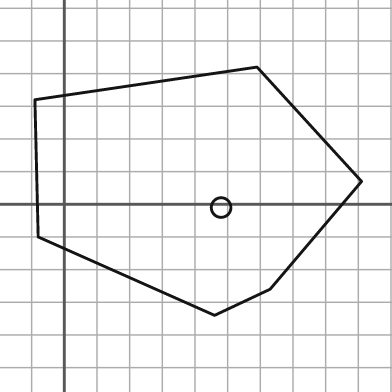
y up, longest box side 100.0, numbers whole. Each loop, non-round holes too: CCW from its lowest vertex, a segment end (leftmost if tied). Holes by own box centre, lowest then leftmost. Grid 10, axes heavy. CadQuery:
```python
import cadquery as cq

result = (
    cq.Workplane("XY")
    .moveTo(46.0, -34.0)
    .lineTo(63.0, -26.0)
    .lineTo(91.0, 7.0)
    .lineTo(59.0, 42.0)
    .lineTo(-9.0, 32.0)
    .lineTo(-8.0, -10.0)
    .close()
    .moveTo(48.0, -1.0)
    .circle(3.0)
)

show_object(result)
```